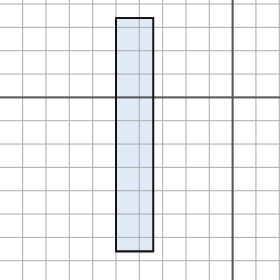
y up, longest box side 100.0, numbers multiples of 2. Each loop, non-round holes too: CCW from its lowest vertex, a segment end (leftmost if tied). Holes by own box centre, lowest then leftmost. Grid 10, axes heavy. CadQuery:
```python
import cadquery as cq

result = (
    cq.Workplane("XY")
    .moveTo(-50.0, -66.0)
    .lineTo(-34.0, -66.0)
    .lineTo(-34.0, 34.0)
    .lineTo(-50.0, 34.0)
    .close()
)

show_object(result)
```